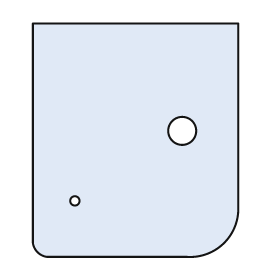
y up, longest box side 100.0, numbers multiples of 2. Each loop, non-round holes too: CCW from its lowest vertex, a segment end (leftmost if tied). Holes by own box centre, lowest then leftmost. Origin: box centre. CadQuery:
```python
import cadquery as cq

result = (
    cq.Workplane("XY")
    .moveTo(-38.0, -50.0)
    .lineTo(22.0, -50.0)
    .threePointArc((38.0, -44.0), (44.0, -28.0))
    .lineTo(44.0, 50.0)
    .lineTo(-44.0, 50.0)
    .lineTo(-44.0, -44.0)
    .threePointArc((-42.0, -48.0), (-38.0, -50.0))
    .close()
    .moveTo(-26.0, -26.0)
    .circle(2.0)
    .moveTo(20.0, 4.0)
    .circle(6.0)
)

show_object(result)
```